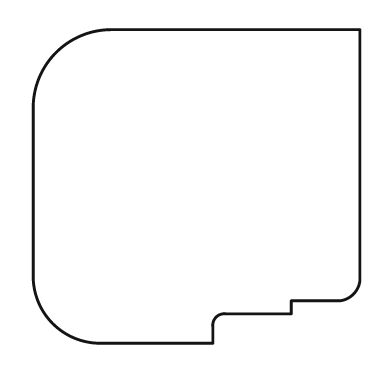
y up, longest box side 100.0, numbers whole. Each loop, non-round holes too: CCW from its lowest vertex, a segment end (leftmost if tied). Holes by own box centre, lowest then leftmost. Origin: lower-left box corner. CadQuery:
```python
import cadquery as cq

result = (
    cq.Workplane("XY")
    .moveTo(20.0, 0.0)
    .lineTo(55.0, 0.0)
    .lineTo(55.0, 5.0)
    .threePointArc((56.0, 8.0), (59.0, 9.0))
    .lineTo(79.0, 9.0)
    .lineTo(79.0, 13.0)
    .lineTo(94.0, 13.0)
    .threePointArc((98.0, 15.0), (100.0, 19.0))
    .lineTo(100.0, 96.0)
    .lineTo(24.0, 96.0)
    .threePointArc((7.0, 89.0), (0.0, 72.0))
    .lineTo(0.0, 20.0)
    .threePointArc((6.0, 6.0), (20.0, 0.0))
    .close()
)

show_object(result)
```